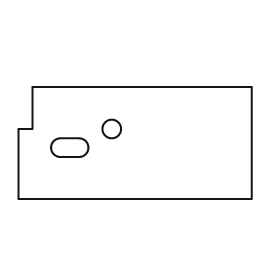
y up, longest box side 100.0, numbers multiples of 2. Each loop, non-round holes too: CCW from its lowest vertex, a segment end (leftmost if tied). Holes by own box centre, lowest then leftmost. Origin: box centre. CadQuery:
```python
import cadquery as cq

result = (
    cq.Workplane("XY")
    .moveTo(-50.0, -24.0)
    .lineTo(50.0, -24.0)
    .lineTo(50.0, 24.0)
    .lineTo(-44.0, 24.0)
    .lineTo(-44.0, 6.0)
    .lineTo(-50.0, 6.0)
    .close()
    .moveTo(-32.0, -6.0)
    .lineTo(-24.0, -6.0)
    .threePointArc((-20.0, -2.0), (-24.0, 2.0))
    .lineTo(-32.0, 2.0)
    .threePointArc((-36.0, -2.0), (-32.0, -6.0))
    .close()
    .moveTo(-10.0, 6.0)
    .circle(4.0)
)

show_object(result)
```